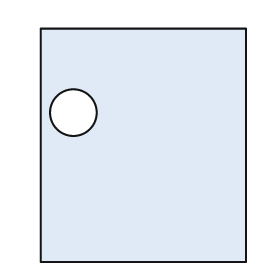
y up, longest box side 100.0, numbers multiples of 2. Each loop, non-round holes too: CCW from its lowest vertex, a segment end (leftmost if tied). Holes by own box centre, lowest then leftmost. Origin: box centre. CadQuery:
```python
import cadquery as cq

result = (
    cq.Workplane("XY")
    .moveTo(-44.0, -50.0)
    .lineTo(44.0, -50.0)
    .lineTo(44.0, 50.0)
    .lineTo(-44.0, 50.0)
    .close()
    .moveTo(-30.0, 14.0)
    .circle(10.0)
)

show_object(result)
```